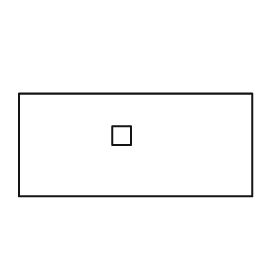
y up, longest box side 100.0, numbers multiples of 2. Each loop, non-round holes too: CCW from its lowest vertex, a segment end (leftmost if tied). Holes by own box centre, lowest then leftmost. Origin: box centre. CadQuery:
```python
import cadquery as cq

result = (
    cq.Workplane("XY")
    .moveTo(-50.0, -22.0)
    .lineTo(50.0, -22.0)
    .lineTo(50.0, 22.0)
    .lineTo(-50.0, 22.0)
    .close()
    .moveTo(-10.0, 0.0)
    .lineTo(-2.0, 0.0)
    .lineTo(-2.0, 8.0)
    .lineTo(-10.0, 8.0)
    .close()
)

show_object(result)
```